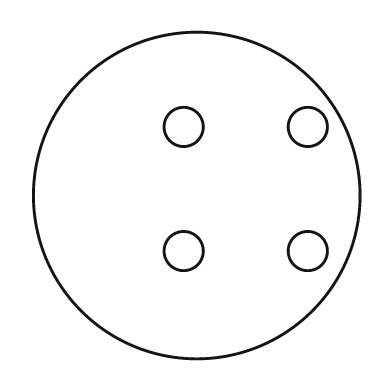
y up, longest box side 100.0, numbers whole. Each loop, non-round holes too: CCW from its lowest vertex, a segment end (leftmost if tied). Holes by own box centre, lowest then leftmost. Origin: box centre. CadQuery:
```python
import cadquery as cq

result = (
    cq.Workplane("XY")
    .moveTo(0.0, 0.0)
    .circle(50.0)
    .moveTo(-4.0, -17.0)
    .circle(6.0)
    .moveTo(34.0, -17.0)
    .circle(6.0)
    .moveTo(-4.0, 21.0)
    .circle(6.0)
    .moveTo(34.0, 21.0)
    .circle(6.0)
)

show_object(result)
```